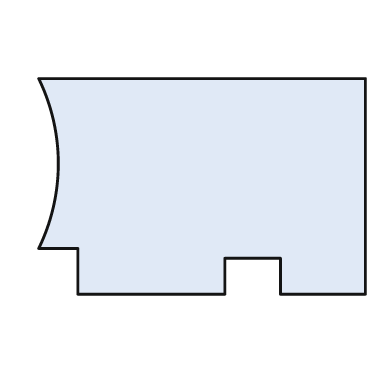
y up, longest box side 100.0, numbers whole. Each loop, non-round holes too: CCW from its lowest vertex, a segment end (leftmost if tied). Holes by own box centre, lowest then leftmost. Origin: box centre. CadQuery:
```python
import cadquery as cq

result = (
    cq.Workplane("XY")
    .moveTo(-38.0, -33.0)
    .lineTo(7.0, -33.0)
    .lineTo(7.0, -22.0)
    .lineTo(24.0, -22.0)
    .lineTo(24.0, -33.0)
    .lineTo(50.0, -33.0)
    .lineTo(50.0, 33.0)
    .lineTo(-50.0, 33.0)
    .threePointArc((-44.0, 7.0), (-50.0, -19.0))
    .lineTo(-38.0, -19.0)
    .close()
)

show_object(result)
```